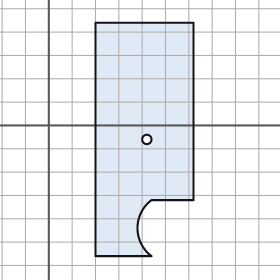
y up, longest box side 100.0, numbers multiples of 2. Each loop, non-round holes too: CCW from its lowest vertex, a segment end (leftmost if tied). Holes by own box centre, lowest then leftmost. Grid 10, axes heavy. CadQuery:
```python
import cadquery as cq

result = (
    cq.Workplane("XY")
    .moveTo(20.0, -56.0)
    .lineTo(44.0, -56.0)
    .threePointArc((38.0, -44.0), (44.0, -32.0))
    .lineTo(62.0, -32.0)
    .lineTo(62.0, 44.0)
    .lineTo(20.0, 44.0)
    .close()
    .moveTo(42.0, -6.0)
    .circle(2.0)
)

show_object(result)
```